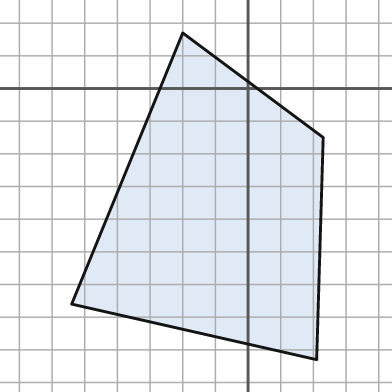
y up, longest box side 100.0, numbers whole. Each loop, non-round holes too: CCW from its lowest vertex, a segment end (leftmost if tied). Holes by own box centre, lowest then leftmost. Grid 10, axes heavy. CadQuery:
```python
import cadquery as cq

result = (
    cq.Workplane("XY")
    .moveTo(21.0, -83.0)
    .lineTo(23.0, -15.0)
    .lineTo(-20.0, 17.0)
    .lineTo(-54.0, -66.0)
    .close()
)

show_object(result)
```